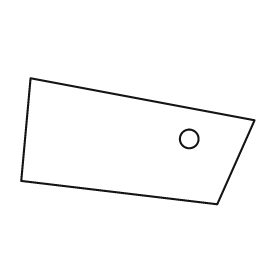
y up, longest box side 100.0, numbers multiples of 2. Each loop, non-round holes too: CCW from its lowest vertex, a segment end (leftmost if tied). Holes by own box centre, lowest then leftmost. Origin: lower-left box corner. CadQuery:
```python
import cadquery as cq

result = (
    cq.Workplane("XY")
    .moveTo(84.0, 0.0)
    .lineTo(100.0, 36.0)
    .lineTo(4.0, 54.0)
    .lineTo(0.0, 10.0)
    .close()
    .moveTo(72.0, 28.0)
    .circle(4.0)
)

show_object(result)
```